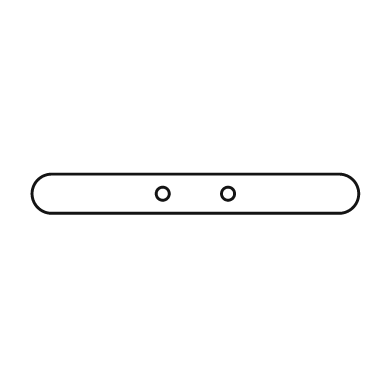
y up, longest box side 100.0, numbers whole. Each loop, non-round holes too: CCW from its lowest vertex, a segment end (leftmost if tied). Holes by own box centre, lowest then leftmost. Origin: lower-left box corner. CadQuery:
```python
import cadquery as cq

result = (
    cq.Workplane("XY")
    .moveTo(6.0, 0.0)
    .lineTo(94.0, 0.0)
    .threePointArc((100.0, 6.0), (94.0, 12.0))
    .lineTo(6.0, 12.0)
    .threePointArc((0.0, 6.0), (6.0, 0.0))
    .close()
    .moveTo(40.0, 6.0)
    .circle(2.0)
    .moveTo(60.0, 6.0)
    .circle(2.0)
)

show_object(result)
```